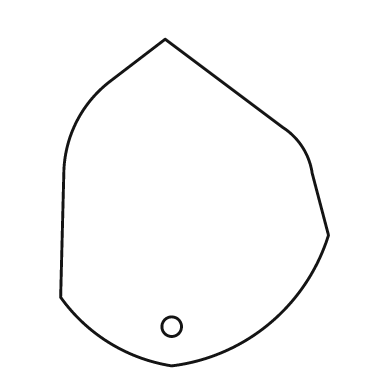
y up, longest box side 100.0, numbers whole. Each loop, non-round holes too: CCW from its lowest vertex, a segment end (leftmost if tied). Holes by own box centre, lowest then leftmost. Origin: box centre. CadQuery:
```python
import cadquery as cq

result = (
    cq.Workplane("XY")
    .moveTo(-7.0, -50.0)
    .threePointArc((23.0, -37.0), (41.0, -10.0))
    .lineTo(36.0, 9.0)
    .threePointArc((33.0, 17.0), (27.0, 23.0))
    .lineTo(-9.0, 50.0)
    .lineTo(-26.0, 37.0)
    .threePointArc((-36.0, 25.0), (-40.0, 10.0))
    .lineTo(-41.0, -29.0)
    .threePointArc((-26.0, -43.0), (-7.0, -50.0))
    .close()
    .moveTo(-7.0, -38.0)
    .circle(3.0)
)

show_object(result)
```